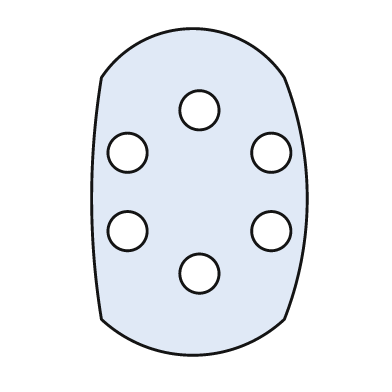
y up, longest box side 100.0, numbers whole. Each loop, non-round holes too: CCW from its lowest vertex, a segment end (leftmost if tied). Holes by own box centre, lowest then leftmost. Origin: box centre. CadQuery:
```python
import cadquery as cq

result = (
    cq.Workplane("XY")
    .moveTo(-30.0, -39.0)
    .threePointArc((-2.0, -50.0), (26.0, -39.0))
    .threePointArc((33.0, -2.0), (26.0, 35.0))
    .threePointArc((-2.0, 50.0), (-30.0, 35.0))
    .threePointArc((-33.0, -2.0), (-30.0, -39.0))
    .close()
    .moveTo(0.0, -25.0)
    .circle(6.0)
    .moveTo(-22.0, -12.0)
    .circle(6.0)
    .moveTo(22.0, -12.0)
    .circle(6.0)
    .moveTo(-22.0, 12.0)
    .circle(6.0)
    .moveTo(22.0, 12.0)
    .circle(6.0)
    .moveTo(0.0, 25.0)
    .circle(6.0)
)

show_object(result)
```